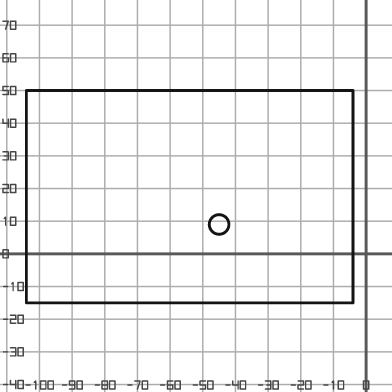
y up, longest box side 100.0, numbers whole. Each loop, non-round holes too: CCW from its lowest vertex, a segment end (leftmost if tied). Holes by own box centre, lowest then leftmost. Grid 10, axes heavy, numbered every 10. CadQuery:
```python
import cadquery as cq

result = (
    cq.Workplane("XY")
    .moveTo(-104.0, -15.0)
    .lineTo(-4.0, -15.0)
    .lineTo(-4.0, 50.0)
    .lineTo(-104.0, 50.0)
    .close()
    .moveTo(-45.0, 9.0)
    .circle(3.0)
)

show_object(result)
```